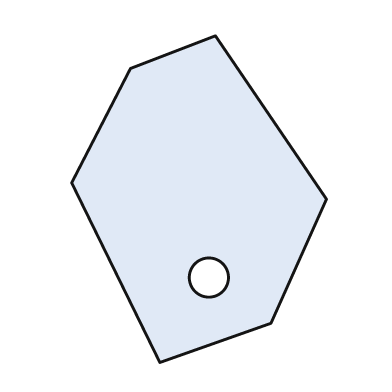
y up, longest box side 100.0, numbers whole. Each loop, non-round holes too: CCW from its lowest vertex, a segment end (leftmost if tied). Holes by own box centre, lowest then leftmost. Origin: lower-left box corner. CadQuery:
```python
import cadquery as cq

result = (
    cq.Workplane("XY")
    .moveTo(27.0, 0.0)
    .lineTo(61.0, 12.0)
    .lineTo(78.0, 50.0)
    .lineTo(44.0, 100.0)
    .lineTo(18.0, 90.0)
    .lineTo(0.0, 55.0)
    .close()
    .moveTo(42.0, 26.0)
    .circle(6.0)
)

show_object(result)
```